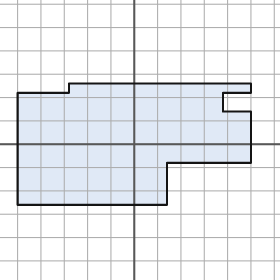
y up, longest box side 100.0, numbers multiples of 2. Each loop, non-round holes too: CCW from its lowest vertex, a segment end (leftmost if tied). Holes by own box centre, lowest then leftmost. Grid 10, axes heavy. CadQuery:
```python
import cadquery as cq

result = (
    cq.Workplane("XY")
    .moveTo(-50.0, -26.0)
    .lineTo(14.0, -26.0)
    .lineTo(14.0, -8.0)
    .lineTo(50.0, -8.0)
    .lineTo(50.0, 14.0)
    .lineTo(38.0, 14.0)
    .lineTo(38.0, 22.0)
    .lineTo(50.0, 22.0)
    .lineTo(50.0, 26.0)
    .lineTo(-28.0, 26.0)
    .lineTo(-28.0, 22.0)
    .lineTo(-50.0, 22.0)
    .close()
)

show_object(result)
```